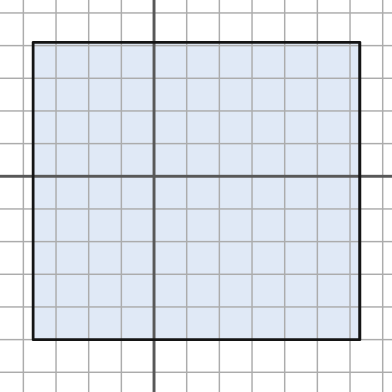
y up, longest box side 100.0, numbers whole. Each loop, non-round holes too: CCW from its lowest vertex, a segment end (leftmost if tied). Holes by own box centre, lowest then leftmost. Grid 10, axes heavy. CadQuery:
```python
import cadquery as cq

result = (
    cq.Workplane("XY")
    .moveTo(-37.0, -50.0)
    .lineTo(63.0, -50.0)
    .lineTo(63.0, 41.0)
    .lineTo(-37.0, 41.0)
    .close()
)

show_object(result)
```